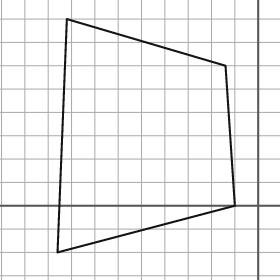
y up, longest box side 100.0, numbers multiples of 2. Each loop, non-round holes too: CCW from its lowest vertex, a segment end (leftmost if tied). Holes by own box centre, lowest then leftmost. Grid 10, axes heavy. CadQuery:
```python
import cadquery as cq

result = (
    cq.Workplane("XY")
    .moveTo(-86.0, -20.0)
    .lineTo(-10.0, 0.0)
    .lineTo(-14.0, 60.0)
    .lineTo(-82.0, 80.0)
    .close()
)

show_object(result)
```